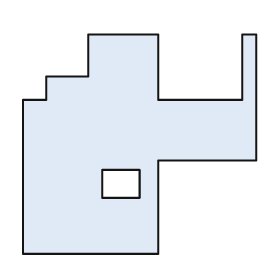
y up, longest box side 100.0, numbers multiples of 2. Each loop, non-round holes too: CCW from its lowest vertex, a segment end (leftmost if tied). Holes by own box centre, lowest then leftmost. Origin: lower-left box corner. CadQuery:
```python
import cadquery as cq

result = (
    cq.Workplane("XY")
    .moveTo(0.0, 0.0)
    .lineTo(58.0, 0.0)
    .lineTo(58.0, 40.0)
    .lineTo(100.0, 40.0)
    .lineTo(100.0, 94.0)
    .lineTo(94.0, 94.0)
    .lineTo(94.0, 66.0)
    .lineTo(58.0, 66.0)
    .lineTo(58.0, 94.0)
    .lineTo(28.0, 94.0)
    .lineTo(28.0, 76.0)
    .lineTo(10.0, 76.0)
    .lineTo(10.0, 66.0)
    .lineTo(0.0, 66.0)
    .close()
    .moveTo(34.0, 24.0)
    .lineTo(50.0, 24.0)
    .lineTo(50.0, 36.0)
    .lineTo(34.0, 36.0)
    .close()
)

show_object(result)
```